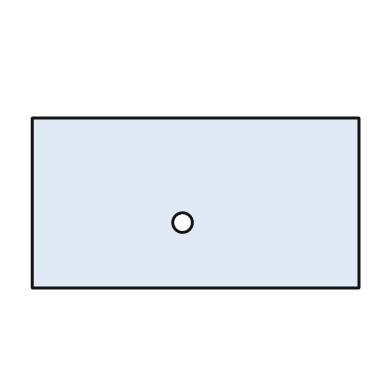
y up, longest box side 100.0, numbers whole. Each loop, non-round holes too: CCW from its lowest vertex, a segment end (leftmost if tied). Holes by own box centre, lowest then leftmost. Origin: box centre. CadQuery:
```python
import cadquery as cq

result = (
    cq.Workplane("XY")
    .moveTo(-50.0, -26.0)
    .lineTo(50.0, -26.0)
    .lineTo(50.0, 26.0)
    .lineTo(-50.0, 26.0)
    .close()
    .moveTo(-4.0, -6.0)
    .circle(3.0)
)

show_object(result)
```